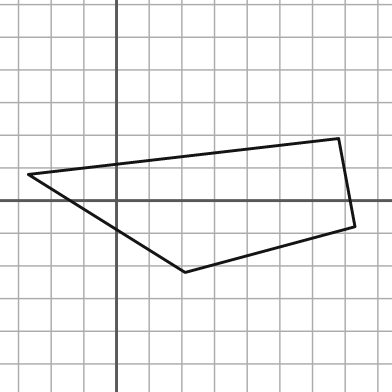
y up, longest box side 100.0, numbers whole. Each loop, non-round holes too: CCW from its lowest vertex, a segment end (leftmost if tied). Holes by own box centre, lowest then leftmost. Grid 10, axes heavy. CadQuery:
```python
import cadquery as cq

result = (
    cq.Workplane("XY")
    .moveTo(21.0, -22.0)
    .lineTo(73.0, -8.0)
    .lineTo(68.0, 19.0)
    .lineTo(-27.0, 8.0)
    .close()
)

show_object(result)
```